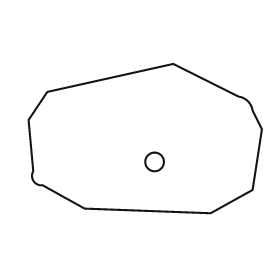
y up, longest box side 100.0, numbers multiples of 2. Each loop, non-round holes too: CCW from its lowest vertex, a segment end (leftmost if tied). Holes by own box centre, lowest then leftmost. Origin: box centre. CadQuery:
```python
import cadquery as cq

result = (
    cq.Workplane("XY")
    .moveTo(28.0, -32.0)
    .lineTo(46.0, -22.0)
    .lineTo(50.0, 4.0)
    .lineTo(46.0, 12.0)
    .threePointArc((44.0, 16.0), (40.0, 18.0))
    .lineTo(12.0, 32.0)
    .lineTo(-42.0, 20.0)
    .lineTo(-50.0, 8.0)
    .lineTo(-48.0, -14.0)
    .threePointArc((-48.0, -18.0), (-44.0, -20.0))
    .lineTo(-26.0, -30.0)
    .close()
    .moveTo(4.0, -10.0)
    .circle(4.0)
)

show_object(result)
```